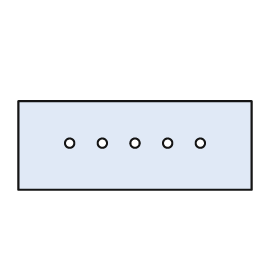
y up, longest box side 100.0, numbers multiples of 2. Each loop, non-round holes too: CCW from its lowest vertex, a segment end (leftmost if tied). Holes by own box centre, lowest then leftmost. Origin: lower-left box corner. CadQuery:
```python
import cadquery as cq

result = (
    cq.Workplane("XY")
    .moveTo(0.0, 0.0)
    .lineTo(100.0, 0.0)
    .lineTo(100.0, 38.0)
    .lineTo(0.0, 38.0)
    .close()
    .moveTo(22.0, 20.0)
    .circle(2.0)
    .moveTo(36.0, 20.0)
    .circle(2.0)
    .moveTo(50.0, 20.0)
    .circle(2.0)
    .moveTo(64.0, 20.0)
    .circle(2.0)
    .moveTo(78.0, 20.0)
    .circle(2.0)
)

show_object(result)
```